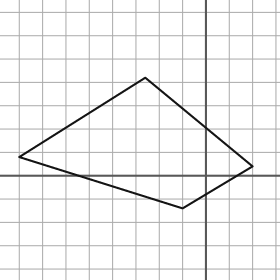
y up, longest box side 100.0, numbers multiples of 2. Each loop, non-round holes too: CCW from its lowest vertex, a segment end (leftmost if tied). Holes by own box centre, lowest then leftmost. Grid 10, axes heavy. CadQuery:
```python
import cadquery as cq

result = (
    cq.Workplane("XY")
    .moveTo(-10.0, -14.0)
    .lineTo(20.0, 4.0)
    .lineTo(-26.0, 42.0)
    .lineTo(-80.0, 8.0)
    .close()
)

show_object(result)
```